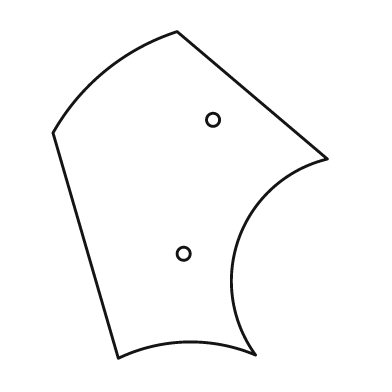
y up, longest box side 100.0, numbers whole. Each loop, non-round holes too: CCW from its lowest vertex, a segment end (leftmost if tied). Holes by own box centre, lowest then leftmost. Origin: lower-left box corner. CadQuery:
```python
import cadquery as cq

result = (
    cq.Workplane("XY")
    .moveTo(20.0, 0.0)
    .threePointArc((41.0, 5.0), (62.0, 1.0))
    .threePointArc((57.0, 37.0), (84.0, 61.0))
    .lineTo(38.0, 100.0)
    .threePointArc((16.0, 88.0), (0.0, 69.0))
    .close()
    .moveTo(40.0, 32.0)
    .circle(2.0)
    .moveTo(49.0, 73.0)
    .circle(2.0)
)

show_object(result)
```